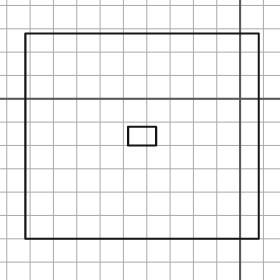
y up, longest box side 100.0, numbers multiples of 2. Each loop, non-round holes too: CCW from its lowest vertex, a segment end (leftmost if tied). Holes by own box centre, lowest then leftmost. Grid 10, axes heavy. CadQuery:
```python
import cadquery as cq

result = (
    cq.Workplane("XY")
    .moveTo(-92.0, -60.0)
    .lineTo(8.0, -60.0)
    .lineTo(8.0, 28.0)
    .lineTo(-92.0, 28.0)
    .close()
    .moveTo(-48.0, -20.0)
    .lineTo(-36.0, -20.0)
    .lineTo(-36.0, -12.0)
    .lineTo(-48.0, -12.0)
    .close()
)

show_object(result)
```